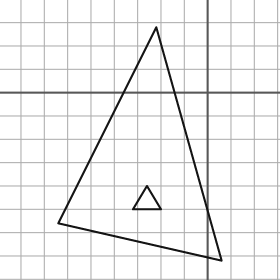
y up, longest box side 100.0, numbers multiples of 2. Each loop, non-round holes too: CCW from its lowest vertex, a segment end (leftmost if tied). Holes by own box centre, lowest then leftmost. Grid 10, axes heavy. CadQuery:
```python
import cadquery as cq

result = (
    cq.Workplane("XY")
    .moveTo(6.0, -72.0)
    .lineTo(-22.0, 28.0)
    .lineTo(-64.0, -56.0)
    .close()
    .moveTo(-32.0, -50.0)
    .lineTo(-20.0, -50.0)
    .lineTo(-26.0, -40.0)
    .close()
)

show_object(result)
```